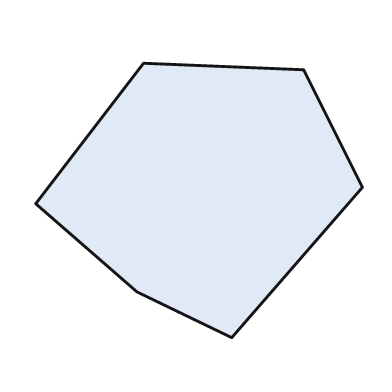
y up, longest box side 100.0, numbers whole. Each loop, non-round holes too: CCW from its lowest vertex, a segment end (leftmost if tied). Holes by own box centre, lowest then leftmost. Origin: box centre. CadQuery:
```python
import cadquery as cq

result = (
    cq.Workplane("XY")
    .moveTo(10.0, -42.0)
    .lineTo(50.0, 4.0)
    .lineTo(32.0, 40.0)
    .lineTo(-17.0, 42.0)
    .lineTo(-50.0, -1.0)
    .lineTo(-19.0, -28.0)
    .close()
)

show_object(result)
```